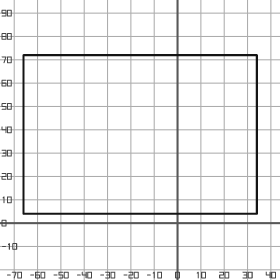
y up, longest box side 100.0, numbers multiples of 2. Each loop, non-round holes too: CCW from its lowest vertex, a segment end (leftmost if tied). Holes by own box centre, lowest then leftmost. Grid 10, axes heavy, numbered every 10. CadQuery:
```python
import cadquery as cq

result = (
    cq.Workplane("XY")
    .moveTo(-66.0, 4.0)
    .lineTo(34.0, 4.0)
    .lineTo(34.0, 72.0)
    .lineTo(-66.0, 72.0)
    .close()
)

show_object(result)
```